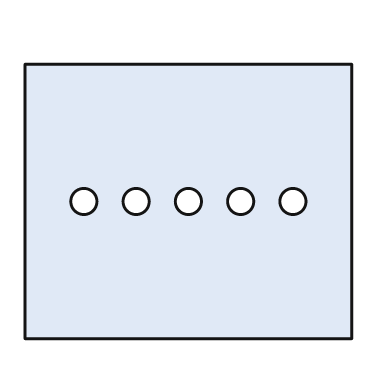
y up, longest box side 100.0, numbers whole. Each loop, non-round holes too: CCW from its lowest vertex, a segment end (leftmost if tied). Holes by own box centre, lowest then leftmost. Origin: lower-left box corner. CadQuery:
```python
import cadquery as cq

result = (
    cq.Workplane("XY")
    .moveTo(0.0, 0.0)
    .lineTo(100.0, 0.0)
    .lineTo(100.0, 84.0)
    .lineTo(0.0, 84.0)
    .close()
    .moveTo(18.0, 42.0)
    .circle(4.0)
    .moveTo(34.0, 42.0)
    .circle(4.0)
    .moveTo(50.0, 42.0)
    .circle(4.0)
    .moveTo(66.0, 42.0)
    .circle(4.0)
    .moveTo(82.0, 42.0)
    .circle(4.0)
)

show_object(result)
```